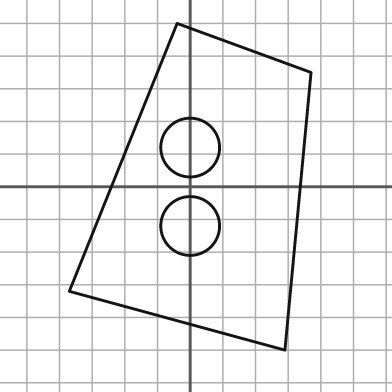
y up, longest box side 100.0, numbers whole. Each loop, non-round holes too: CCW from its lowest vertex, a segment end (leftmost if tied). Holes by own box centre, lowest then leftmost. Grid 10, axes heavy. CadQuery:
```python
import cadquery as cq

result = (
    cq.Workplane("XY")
    .moveTo(29.0, -50.0)
    .lineTo(37.0, 35.0)
    .lineTo(-4.0, 50.0)
    .lineTo(-37.0, -32.0)
    .close()
    .moveTo(0.0, -12.0)
    .circle(9.0)
    .moveTo(0.0, 12.0)
    .circle(9.0)
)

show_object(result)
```